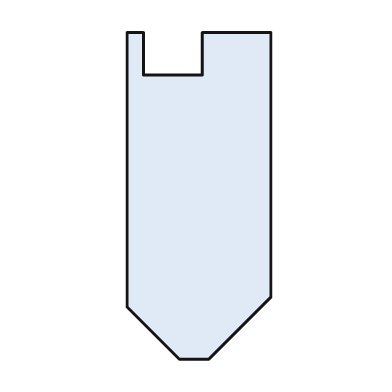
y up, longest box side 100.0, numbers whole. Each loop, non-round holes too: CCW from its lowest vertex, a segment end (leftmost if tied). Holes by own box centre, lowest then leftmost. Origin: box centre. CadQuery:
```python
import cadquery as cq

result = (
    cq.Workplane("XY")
    .moveTo(-6.0, -50.0)
    .lineTo(3.0, -50.0)
    .lineTo(22.0, -31.0)
    .lineTo(22.0, 50.0)
    .lineTo(1.0, 50.0)
    .lineTo(1.0, 37.0)
    .lineTo(-17.0, 37.0)
    .lineTo(-17.0, 50.0)
    .lineTo(-22.0, 50.0)
    .lineTo(-22.0, -34.0)
    .close()
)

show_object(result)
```